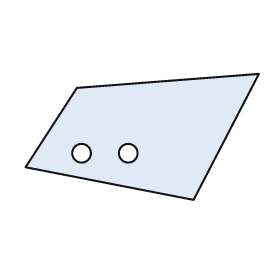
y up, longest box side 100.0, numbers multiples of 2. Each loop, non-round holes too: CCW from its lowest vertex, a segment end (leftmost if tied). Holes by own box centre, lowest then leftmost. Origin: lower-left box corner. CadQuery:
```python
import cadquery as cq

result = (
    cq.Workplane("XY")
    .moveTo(72.0, 0.0)
    .lineTo(100.0, 54.0)
    .lineTo(22.0, 48.0)
    .lineTo(0.0, 14.0)
    .close()
    .moveTo(24.0, 20.0)
    .circle(4.0)
    .moveTo(44.0, 20.0)
    .circle(4.0)
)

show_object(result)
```